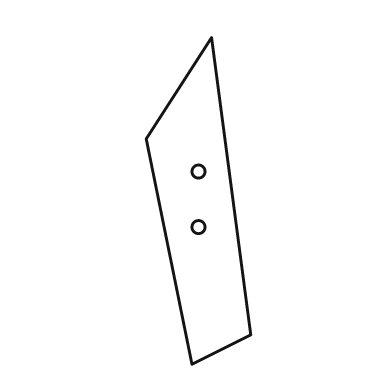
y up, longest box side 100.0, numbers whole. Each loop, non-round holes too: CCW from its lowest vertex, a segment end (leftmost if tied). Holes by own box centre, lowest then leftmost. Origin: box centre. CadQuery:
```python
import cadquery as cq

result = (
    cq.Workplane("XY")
    .moveTo(-2.0, -50.0)
    .lineTo(16.0, -41.0)
    .lineTo(4.0, 50.0)
    .lineTo(-16.0, 19.0)
    .close()
    .moveTo(0.0, -8.0)
    .circle(2.0)
    .moveTo(0.0, 9.0)
    .circle(2.0)
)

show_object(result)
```